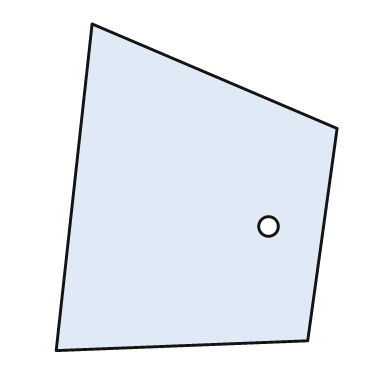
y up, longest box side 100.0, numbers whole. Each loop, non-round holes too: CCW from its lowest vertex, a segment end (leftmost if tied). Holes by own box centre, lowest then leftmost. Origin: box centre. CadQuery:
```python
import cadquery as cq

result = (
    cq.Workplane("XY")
    .moveTo(-43.0, -50.0)
    .lineTo(34.0, -47.0)
    .lineTo(43.0, 18.0)
    .lineTo(-32.0, 50.0)
    .close()
    .moveTo(22.0, -12.0)
    .circle(3.0)
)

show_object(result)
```